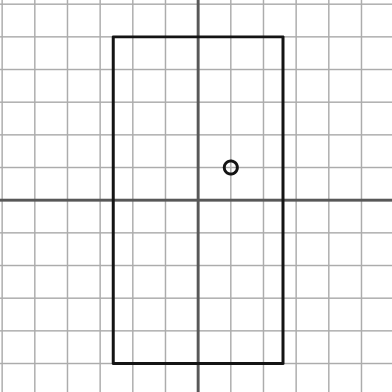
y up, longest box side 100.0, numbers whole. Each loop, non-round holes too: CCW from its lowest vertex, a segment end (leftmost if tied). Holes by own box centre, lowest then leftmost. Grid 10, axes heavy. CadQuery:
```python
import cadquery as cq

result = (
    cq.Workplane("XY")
    .moveTo(-26.0, -50.0)
    .lineTo(26.0, -50.0)
    .lineTo(26.0, 50.0)
    .lineTo(-26.0, 50.0)
    .close()
    .moveTo(10.0, 10.0)
    .circle(2.0)
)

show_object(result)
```